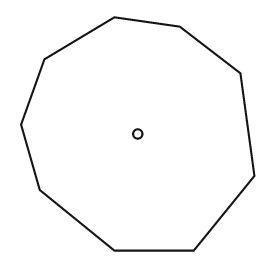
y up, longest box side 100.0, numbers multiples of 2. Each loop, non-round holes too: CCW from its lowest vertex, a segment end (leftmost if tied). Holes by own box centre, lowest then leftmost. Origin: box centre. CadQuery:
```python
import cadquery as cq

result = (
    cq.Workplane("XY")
    .moveTo(-10.0, -50.0)
    .lineTo(24.0, -50.0)
    .lineTo(50.0, -18.0)
    .lineTo(44.0, 26.0)
    .lineTo(18.0, 46.0)
    .lineTo(-10.0, 50.0)
    .lineTo(-40.0, 32.0)
    .lineTo(-50.0, 4.0)
    .lineTo(-42.0, -24.0)
    .close()
    .moveTo(0.0, 0.0)
    .circle(2.0)
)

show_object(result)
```